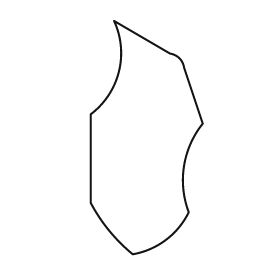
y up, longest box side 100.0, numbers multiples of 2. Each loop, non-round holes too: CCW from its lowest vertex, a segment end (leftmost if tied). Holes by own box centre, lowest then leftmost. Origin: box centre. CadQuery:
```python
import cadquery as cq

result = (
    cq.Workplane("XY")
    .moveTo(-6.0, -50.0)
    .threePointArc((8.0, -44.0), (18.0, -32.0))
    .threePointArc((16.0, -12.0), (24.0, 6.0))
    .lineTo(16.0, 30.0)
    .threePointArc((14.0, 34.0), (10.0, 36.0))
    .lineTo(-14.0, 50.0)
    .threePointArc((-12.0, 28.0), (-24.0, 10.0))
    .lineTo(-24.0, -28.0)
    .threePointArc((-16.0, -40.0), (-6.0, -50.0))
    .close()
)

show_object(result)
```